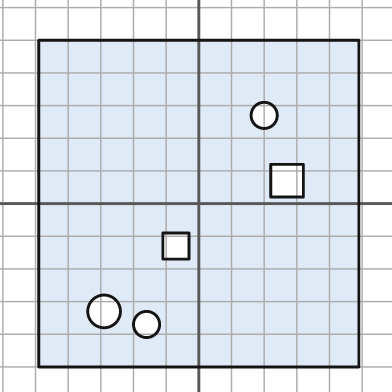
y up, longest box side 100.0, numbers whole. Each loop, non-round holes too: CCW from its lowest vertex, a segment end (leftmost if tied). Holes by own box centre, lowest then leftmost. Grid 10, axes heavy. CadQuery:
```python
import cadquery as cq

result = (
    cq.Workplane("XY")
    .moveTo(-49.0, -50.0)
    .lineTo(49.0, -50.0)
    .lineTo(49.0, 50.0)
    .lineTo(-49.0, 50.0)
    .close()
    .moveTo(-16.0, -37.0)
    .circle(4.0)
    .moveTo(-29.0, -33.0)
    .circle(5.0)
    .moveTo(-11.0, -17.0)
    .lineTo(-3.0, -17.0)
    .lineTo(-3.0, -9.0)
    .lineTo(-11.0, -9.0)
    .close()
    .moveTo(22.0, 2.0)
    .lineTo(32.0, 2.0)
    .lineTo(32.0, 12.0)
    .lineTo(22.0, 12.0)
    .close()
    .moveTo(20.0, 27.0)
    .circle(4.0)
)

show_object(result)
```